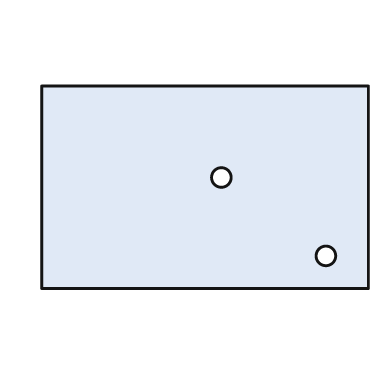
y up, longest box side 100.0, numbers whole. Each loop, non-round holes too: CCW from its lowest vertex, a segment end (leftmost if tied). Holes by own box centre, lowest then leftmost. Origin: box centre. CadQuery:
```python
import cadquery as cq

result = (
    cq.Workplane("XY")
    .moveTo(-50.0, -31.0)
    .lineTo(50.0, -31.0)
    .lineTo(50.0, 31.0)
    .lineTo(-50.0, 31.0)
    .close()
    .moveTo(37.0, -21.0)
    .circle(3.0)
    .moveTo(5.0, 3.0)
    .circle(3.0)
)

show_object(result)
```